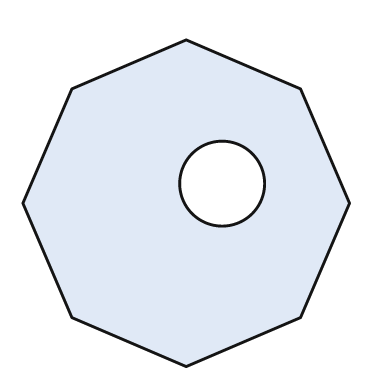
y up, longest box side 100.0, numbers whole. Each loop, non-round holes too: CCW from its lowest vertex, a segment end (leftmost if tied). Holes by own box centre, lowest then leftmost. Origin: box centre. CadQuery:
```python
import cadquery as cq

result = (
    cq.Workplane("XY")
    .moveTo(0.0, -50.0)
    .lineTo(35.0, -35.0)
    .lineTo(50.0, 0.0)
    .lineTo(35.0, 35.0)
    .lineTo(0.0, 50.0)
    .lineTo(-35.0, 35.0)
    .lineTo(-50.0, 0.0)
    .lineTo(-35.0, -35.0)
    .close()
    .moveTo(11.0, 6.0)
    .circle(13.0)
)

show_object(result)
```